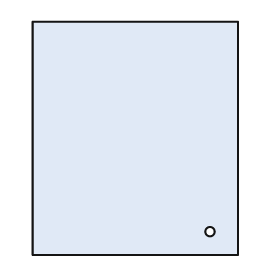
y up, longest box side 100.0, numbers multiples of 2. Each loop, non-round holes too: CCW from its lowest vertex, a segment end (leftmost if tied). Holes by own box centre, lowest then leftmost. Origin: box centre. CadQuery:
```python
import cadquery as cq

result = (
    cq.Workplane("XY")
    .moveTo(-44.0, -50.0)
    .lineTo(44.0, -50.0)
    .lineTo(44.0, 50.0)
    .lineTo(-44.0, 50.0)
    .close()
    .moveTo(32.0, -40.0)
    .circle(2.0)
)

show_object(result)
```